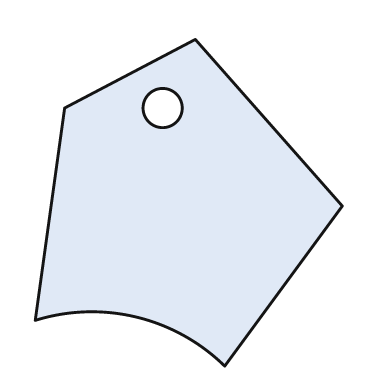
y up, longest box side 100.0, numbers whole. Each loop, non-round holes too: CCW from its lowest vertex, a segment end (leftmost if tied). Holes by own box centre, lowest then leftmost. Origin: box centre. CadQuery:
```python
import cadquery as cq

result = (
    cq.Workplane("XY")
    .moveTo(11.0, -50.0)
    .lineTo(47.0, -1.0)
    .lineTo(2.0, 50.0)
    .lineTo(-38.0, 29.0)
    .lineTo(-47.0, -36.0)
    .threePointArc((-16.0, -35.0), (11.0, -50.0))
    .close()
    .moveTo(-8.0, 29.0)
    .circle(6.0)
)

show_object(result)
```